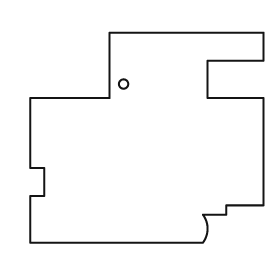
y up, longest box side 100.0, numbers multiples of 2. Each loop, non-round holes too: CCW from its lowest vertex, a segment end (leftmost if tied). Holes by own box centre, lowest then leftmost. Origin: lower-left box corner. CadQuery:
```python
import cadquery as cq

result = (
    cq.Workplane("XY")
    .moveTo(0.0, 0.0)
    .lineTo(74.0, 0.0)
    .threePointArc((76.0, 6.0), (74.0, 12.0))
    .lineTo(84.0, 12.0)
    .lineTo(84.0, 16.0)
    .lineTo(100.0, 16.0)
    .lineTo(100.0, 62.0)
    .lineTo(76.0, 62.0)
    .lineTo(76.0, 78.0)
    .lineTo(100.0, 78.0)
    .lineTo(100.0, 90.0)
    .lineTo(34.0, 90.0)
    .lineTo(34.0, 62.0)
    .lineTo(0.0, 62.0)
    .lineTo(0.0, 32.0)
    .lineTo(6.0, 32.0)
    .lineTo(6.0, 20.0)
    .lineTo(0.0, 20.0)
    .close()
    .moveTo(40.0, 68.0)
    .circle(2.0)
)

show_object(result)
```